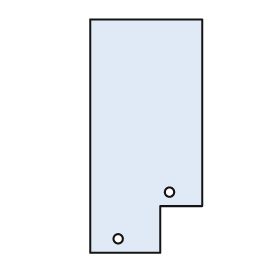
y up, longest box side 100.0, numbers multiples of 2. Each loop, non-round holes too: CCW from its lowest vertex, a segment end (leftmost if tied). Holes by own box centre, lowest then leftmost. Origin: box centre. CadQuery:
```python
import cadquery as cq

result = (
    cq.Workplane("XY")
    .moveTo(-24.0, -50.0)
    .lineTo(6.0, -50.0)
    .lineTo(6.0, -30.0)
    .lineTo(24.0, -30.0)
    .lineTo(24.0, 50.0)
    .lineTo(-24.0, 50.0)
    .close()
    .moveTo(-12.0, -44.0)
    .circle(2.0)
    .moveTo(10.0, -24.0)
    .circle(2.0)
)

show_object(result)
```